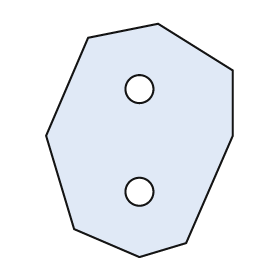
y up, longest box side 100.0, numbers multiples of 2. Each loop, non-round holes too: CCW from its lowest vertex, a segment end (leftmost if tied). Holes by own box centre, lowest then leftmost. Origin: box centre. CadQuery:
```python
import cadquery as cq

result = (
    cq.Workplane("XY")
    .moveTo(0.0, -50.0)
    .lineTo(20.0, -44.0)
    .lineTo(40.0, 2.0)
    .lineTo(40.0, 30.0)
    .lineTo(8.0, 50.0)
    .lineTo(-22.0, 44.0)
    .lineTo(-40.0, 2.0)
    .lineTo(-28.0, -38.0)
    .close()
    .moveTo(0.0, -22.0)
    .circle(6.0)
    .moveTo(0.0, 22.0)
    .circle(6.0)
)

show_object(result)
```